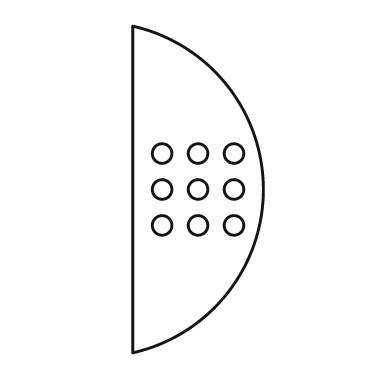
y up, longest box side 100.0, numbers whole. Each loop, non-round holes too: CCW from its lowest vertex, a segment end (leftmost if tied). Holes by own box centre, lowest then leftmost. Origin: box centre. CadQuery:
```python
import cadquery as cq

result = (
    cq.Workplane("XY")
    .moveTo(-20.0, -50.0)
    .threePointArc((20.0, 0.0), (-20.0, 50.0))
    .close()
    .moveTo(-11.0, -11.0)
    .circle(3.0)
    .moveTo(0.0, -11.0)
    .circle(3.0)
    .moveTo(11.0, -11.0)
    .circle(3.0)
    .moveTo(-11.0, 0.0)
    .circle(3.0)
    .moveTo(0.0, 0.0)
    .circle(3.0)
    .moveTo(11.0, 0.0)
    .circle(3.0)
    .moveTo(-11.0, 11.0)
    .circle(3.0)
    .moveTo(0.0, 11.0)
    .circle(3.0)
    .moveTo(11.0, 11.0)
    .circle(3.0)
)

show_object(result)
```